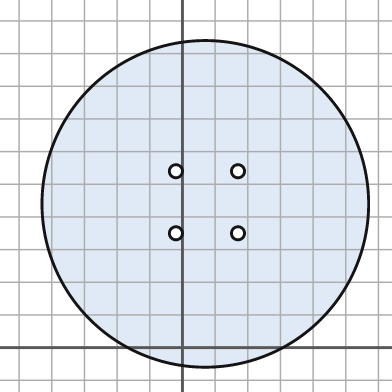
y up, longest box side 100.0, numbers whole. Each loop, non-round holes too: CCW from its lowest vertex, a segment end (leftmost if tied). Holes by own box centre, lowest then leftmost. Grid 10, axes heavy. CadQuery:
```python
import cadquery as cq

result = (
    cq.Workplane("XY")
    .moveTo(7.0, 44.0)
    .circle(50.0)
    .moveTo(-2.0, 35.0)
    .circle(2.0)
    .moveTo(17.0, 35.0)
    .circle(2.0)
    .moveTo(-2.0, 54.0)
    .circle(2.0)
    .moveTo(17.0, 54.0)
    .circle(2.0)
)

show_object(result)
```